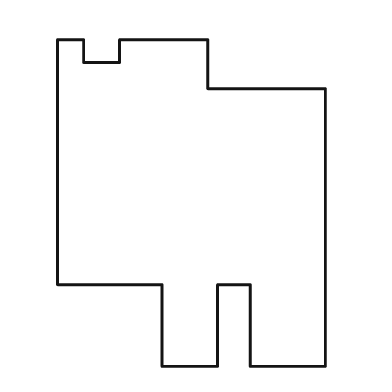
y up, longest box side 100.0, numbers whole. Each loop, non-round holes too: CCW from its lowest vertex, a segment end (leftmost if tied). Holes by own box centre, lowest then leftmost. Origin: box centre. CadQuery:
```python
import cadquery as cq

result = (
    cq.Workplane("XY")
    .moveTo(-9.0, -50.0)
    .lineTo(8.0, -50.0)
    .lineTo(8.0, -25.0)
    .lineTo(18.0, -25.0)
    .lineTo(18.0, -50.0)
    .lineTo(41.0, -50.0)
    .lineTo(41.0, 35.0)
    .lineTo(5.0, 35.0)
    .lineTo(5.0, 50.0)
    .lineTo(-22.0, 50.0)
    .lineTo(-22.0, 43.0)
    .lineTo(-33.0, 43.0)
    .lineTo(-33.0, 50.0)
    .lineTo(-41.0, 50.0)
    .lineTo(-41.0, -25.0)
    .lineTo(-9.0, -25.0)
    .close()
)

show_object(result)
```